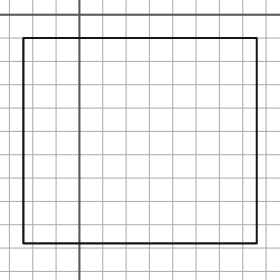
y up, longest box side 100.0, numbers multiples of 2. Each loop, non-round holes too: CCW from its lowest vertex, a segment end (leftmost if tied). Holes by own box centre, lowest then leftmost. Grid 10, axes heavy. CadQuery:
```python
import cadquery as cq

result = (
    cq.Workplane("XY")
    .moveTo(-24.0, -98.0)
    .lineTo(76.0, -98.0)
    .lineTo(76.0, -10.0)
    .lineTo(-24.0, -10.0)
    .close()
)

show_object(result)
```